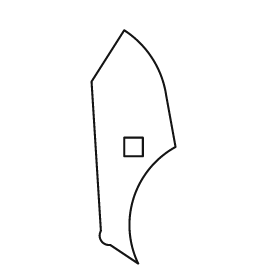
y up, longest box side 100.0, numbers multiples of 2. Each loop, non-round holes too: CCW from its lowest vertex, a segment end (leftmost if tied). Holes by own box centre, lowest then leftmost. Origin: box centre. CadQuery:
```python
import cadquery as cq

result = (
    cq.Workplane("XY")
    .moveTo(2.0, -50.0)
    .threePointArc((0.0, -22.0), (18.0, 0.0))
    .lineTo(14.0, 22.0)
    .threePointArc((8.0, 38.0), (-4.0, 50.0))
    .lineTo(-18.0, 28.0)
    .lineTo(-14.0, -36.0)
    .threePointArc((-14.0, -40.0), (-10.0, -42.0))
    .close()
    .moveTo(-4.0, -4.0)
    .lineTo(4.0, -4.0)
    .lineTo(4.0, 4.0)
    .lineTo(-4.0, 4.0)
    .close()
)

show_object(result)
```